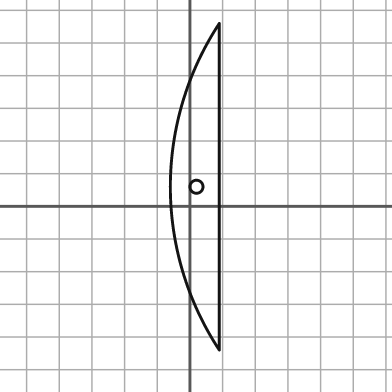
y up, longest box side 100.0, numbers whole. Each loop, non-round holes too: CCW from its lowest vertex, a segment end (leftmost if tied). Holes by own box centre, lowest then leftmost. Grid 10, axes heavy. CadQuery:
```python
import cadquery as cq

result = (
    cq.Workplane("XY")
    .moveTo(9.0, -44.0)
    .lineTo(9.0, 56.0)
    .threePointArc((-6.0, 6.0), (9.0, -44.0))
    .close()
    .moveTo(2.0, 6.0)
    .circle(2.0)
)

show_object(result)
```